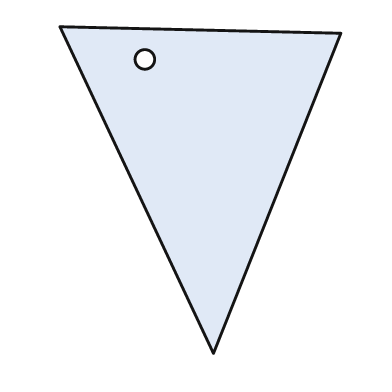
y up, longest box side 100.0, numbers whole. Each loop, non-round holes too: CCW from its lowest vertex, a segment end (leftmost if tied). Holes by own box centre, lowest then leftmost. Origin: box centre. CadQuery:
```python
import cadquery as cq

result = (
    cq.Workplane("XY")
    .moveTo(4.0, -50.0)
    .lineTo(43.0, 48.0)
    .lineTo(-43.0, 50.0)
    .close()
    .moveTo(-17.0, 40.0)
    .circle(3.0)
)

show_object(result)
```